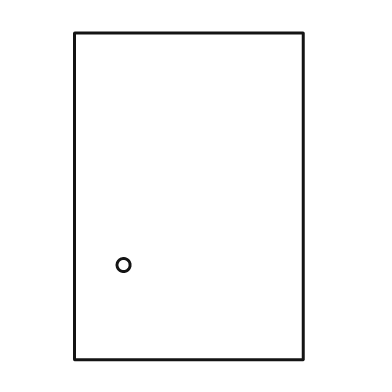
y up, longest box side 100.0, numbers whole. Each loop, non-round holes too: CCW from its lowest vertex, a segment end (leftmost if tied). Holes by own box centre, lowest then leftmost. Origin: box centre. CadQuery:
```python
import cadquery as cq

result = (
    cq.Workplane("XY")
    .moveTo(-35.0, -50.0)
    .lineTo(35.0, -50.0)
    .lineTo(35.0, 50.0)
    .lineTo(-35.0, 50.0)
    .close()
    .moveTo(-20.0, -21.0)
    .circle(2.0)
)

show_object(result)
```